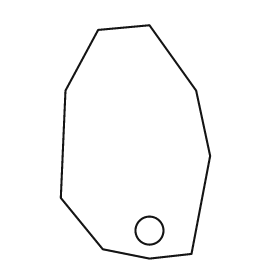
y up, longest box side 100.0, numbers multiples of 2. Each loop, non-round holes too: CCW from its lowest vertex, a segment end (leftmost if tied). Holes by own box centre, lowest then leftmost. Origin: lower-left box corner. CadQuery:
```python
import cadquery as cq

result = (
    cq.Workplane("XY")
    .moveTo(38.0, 0.0)
    .lineTo(56.0, 2.0)
    .lineTo(64.0, 44.0)
    .lineTo(58.0, 72.0)
    .lineTo(38.0, 100.0)
    .lineTo(16.0, 98.0)
    .lineTo(2.0, 72.0)
    .lineTo(0.0, 26.0)
    .lineTo(18.0, 4.0)
    .close()
    .moveTo(38.0, 12.0)
    .circle(6.0)
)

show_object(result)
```